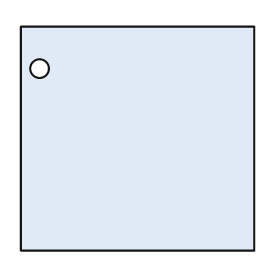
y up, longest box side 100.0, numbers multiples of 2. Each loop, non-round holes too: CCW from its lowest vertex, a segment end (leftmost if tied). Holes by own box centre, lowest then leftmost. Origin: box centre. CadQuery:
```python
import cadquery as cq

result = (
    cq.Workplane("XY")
    .moveTo(-50.0, -48.0)
    .lineTo(50.0, -48.0)
    .lineTo(50.0, 48.0)
    .lineTo(-50.0, 48.0)
    .close()
    .moveTo(-42.0, 30.0)
    .circle(4.0)
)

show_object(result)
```